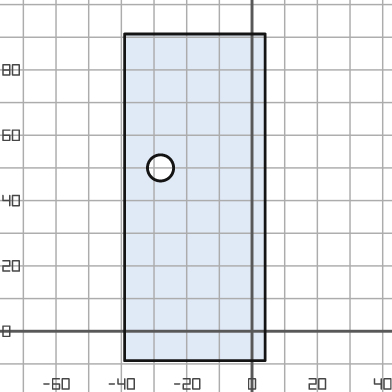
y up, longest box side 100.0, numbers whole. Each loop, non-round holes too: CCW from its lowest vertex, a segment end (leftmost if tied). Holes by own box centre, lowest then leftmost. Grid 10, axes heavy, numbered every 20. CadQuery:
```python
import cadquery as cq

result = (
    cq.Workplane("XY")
    .moveTo(-39.0, -9.0)
    .lineTo(4.0, -9.0)
    .lineTo(4.0, 91.0)
    .lineTo(-39.0, 91.0)
    .close()
    .moveTo(-28.0, 50.0)
    .circle(4.0)
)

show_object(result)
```